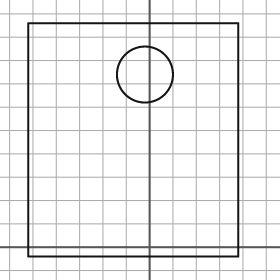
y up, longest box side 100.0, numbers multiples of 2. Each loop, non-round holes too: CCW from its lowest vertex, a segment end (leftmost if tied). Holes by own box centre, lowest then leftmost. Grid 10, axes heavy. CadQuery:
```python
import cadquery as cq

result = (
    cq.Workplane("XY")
    .moveTo(-52.0, -4.0)
    .lineTo(38.0, -4.0)
    .lineTo(38.0, 96.0)
    .lineTo(-52.0, 96.0)
    .close()
    .moveTo(-2.0, 74.0)
    .circle(12.0)
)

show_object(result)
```